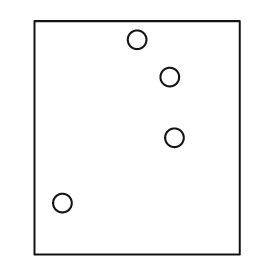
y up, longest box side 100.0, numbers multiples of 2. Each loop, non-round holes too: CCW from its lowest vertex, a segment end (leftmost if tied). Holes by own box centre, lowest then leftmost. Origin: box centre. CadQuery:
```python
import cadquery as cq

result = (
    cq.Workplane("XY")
    .moveTo(-44.0, -50.0)
    .lineTo(44.0, -50.0)
    .lineTo(44.0, 50.0)
    .lineTo(-44.0, 50.0)
    .close()
    .moveTo(-32.0, -28.0)
    .circle(4.0)
    .moveTo(16.0, 0.0)
    .circle(4.0)
    .moveTo(14.0, 26.0)
    .circle(4.0)
    .moveTo(0.0, 42.0)
    .circle(4.0)
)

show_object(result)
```